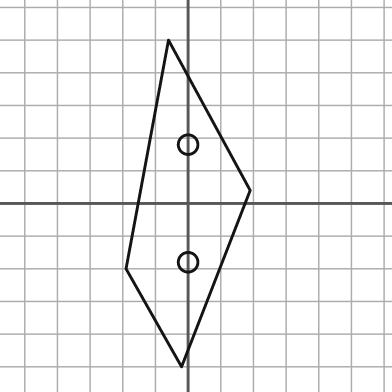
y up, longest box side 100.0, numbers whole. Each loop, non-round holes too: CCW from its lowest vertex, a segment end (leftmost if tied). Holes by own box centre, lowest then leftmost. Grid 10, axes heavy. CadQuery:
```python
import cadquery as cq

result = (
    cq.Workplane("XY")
    .moveTo(-2.0, -50.0)
    .lineTo(19.0, 4.0)
    .lineTo(-6.0, 50.0)
    .lineTo(-19.0, -20.0)
    .close()
    .moveTo(0.0, -18.0)
    .circle(3.0)
    .moveTo(0.0, 18.0)
    .circle(3.0)
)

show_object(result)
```